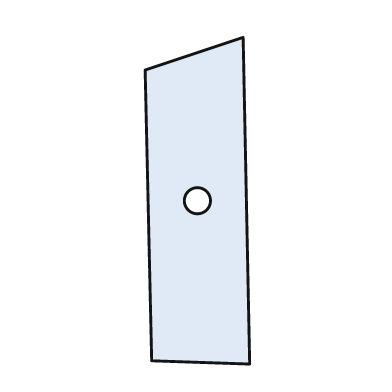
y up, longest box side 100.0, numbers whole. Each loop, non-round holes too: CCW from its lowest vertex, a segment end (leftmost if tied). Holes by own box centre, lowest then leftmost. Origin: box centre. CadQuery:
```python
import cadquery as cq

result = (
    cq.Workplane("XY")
    .moveTo(16.0, -50.0)
    .lineTo(14.0, 50.0)
    .lineTo(-16.0, 40.0)
    .lineTo(-14.0, -49.0)
    .close()
    .moveTo(0.0, 0.0)
    .circle(4.0)
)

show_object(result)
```